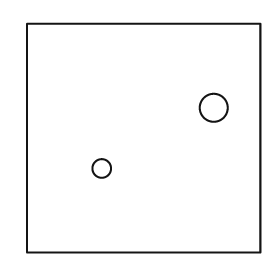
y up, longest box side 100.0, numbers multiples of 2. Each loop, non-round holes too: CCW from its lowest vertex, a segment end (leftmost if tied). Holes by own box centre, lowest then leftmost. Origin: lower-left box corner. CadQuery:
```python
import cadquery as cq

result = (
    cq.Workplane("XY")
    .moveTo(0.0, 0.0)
    .lineTo(100.0, 0.0)
    .lineTo(100.0, 98.0)
    .lineTo(0.0, 98.0)
    .close()
    .moveTo(32.0, 36.0)
    .circle(4.0)
    .moveTo(80.0, 62.0)
    .circle(6.0)
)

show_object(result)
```